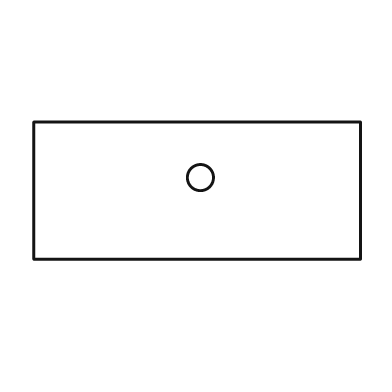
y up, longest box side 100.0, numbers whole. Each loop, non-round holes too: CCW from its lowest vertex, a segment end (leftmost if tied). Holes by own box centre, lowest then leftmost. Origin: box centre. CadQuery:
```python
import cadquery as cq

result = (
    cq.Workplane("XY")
    .moveTo(-50.0, -21.0)
    .lineTo(50.0, -21.0)
    .lineTo(50.0, 21.0)
    .lineTo(-50.0, 21.0)
    .close()
    .moveTo(1.0, 4.0)
    .circle(4.0)
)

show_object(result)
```